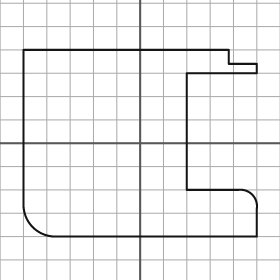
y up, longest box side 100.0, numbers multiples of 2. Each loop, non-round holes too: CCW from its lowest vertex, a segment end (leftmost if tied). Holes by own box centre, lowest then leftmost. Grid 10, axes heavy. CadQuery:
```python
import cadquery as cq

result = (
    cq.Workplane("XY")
    .moveTo(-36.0, -40.0)
    .lineTo(50.0, -40.0)
    .lineTo(50.0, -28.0)
    .threePointArc((48.0, -22.0), (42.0, -20.0))
    .lineTo(20.0, -20.0)
    .lineTo(20.0, 30.0)
    .lineTo(50.0, 30.0)
    .lineTo(50.0, 34.0)
    .lineTo(38.0, 34.0)
    .lineTo(38.0, 40.0)
    .lineTo(-50.0, 40.0)
    .lineTo(-50.0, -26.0)
    .threePointArc((-46.0, -36.0), (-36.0, -40.0))
    .close()
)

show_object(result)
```